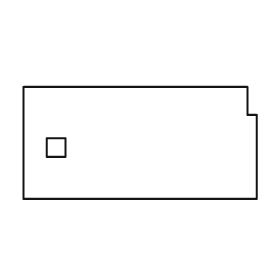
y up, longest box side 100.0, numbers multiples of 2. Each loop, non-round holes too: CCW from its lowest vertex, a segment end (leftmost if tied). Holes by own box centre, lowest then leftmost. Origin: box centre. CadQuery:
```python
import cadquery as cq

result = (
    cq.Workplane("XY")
    .moveTo(-50.0, -24.0)
    .lineTo(50.0, -24.0)
    .lineTo(50.0, 12.0)
    .lineTo(46.0, 12.0)
    .lineTo(46.0, 24.0)
    .lineTo(-50.0, 24.0)
    .close()
    .moveTo(-40.0, -6.0)
    .lineTo(-32.0, -6.0)
    .lineTo(-32.0, 2.0)
    .lineTo(-40.0, 2.0)
    .close()
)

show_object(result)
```